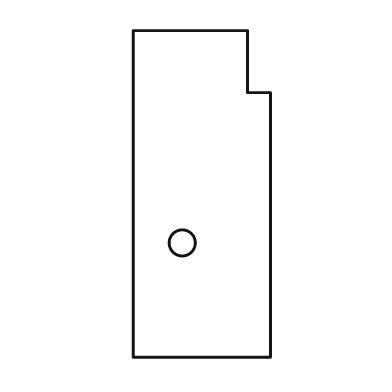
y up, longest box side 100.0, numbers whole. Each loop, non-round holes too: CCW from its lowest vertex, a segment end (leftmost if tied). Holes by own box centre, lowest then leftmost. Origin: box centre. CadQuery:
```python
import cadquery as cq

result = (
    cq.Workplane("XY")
    .moveTo(-21.0, -50.0)
    .lineTo(21.0, -50.0)
    .lineTo(21.0, 31.0)
    .lineTo(14.0, 31.0)
    .lineTo(14.0, 50.0)
    .lineTo(-21.0, 50.0)
    .close()
    .moveTo(-6.0, -15.0)
    .circle(4.0)
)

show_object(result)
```